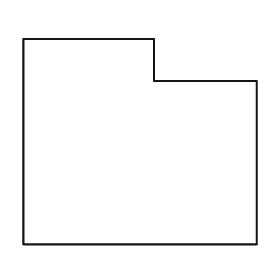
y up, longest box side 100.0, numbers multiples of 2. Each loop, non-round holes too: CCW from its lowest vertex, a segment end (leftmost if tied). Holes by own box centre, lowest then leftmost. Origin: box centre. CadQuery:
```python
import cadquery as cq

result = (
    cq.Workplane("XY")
    .moveTo(-50.0, -44.0)
    .lineTo(50.0, -44.0)
    .lineTo(50.0, 26.0)
    .lineTo(6.0, 26.0)
    .lineTo(6.0, 44.0)
    .lineTo(-50.0, 44.0)
    .close()
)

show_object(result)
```